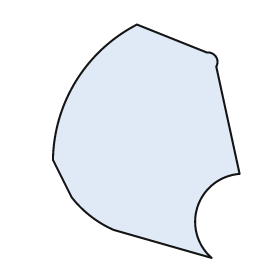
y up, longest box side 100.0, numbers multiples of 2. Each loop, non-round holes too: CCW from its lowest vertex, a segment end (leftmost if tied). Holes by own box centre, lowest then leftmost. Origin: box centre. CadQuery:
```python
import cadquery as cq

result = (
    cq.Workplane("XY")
    .moveTo(28.0, -50.0)
    .threePointArc((22.0, -28.0), (40.0, -14.0))
    .lineTo(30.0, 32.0)
    .threePointArc((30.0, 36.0), (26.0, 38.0))
    .lineTo(-4.0, 50.0)
    .threePointArc((-30.0, 26.0), (-40.0, -8.0))
    .lineTo(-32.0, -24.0)
    .threePointArc((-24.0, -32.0), (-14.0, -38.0))
    .close()
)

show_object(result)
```